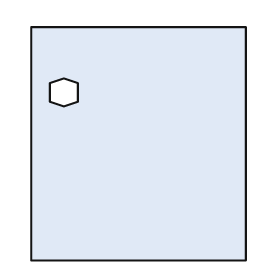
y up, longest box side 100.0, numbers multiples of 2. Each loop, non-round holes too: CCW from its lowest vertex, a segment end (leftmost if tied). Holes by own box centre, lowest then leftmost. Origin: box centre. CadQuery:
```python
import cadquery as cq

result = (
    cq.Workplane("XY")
    .moveTo(-46.0, -50.0)
    .lineTo(46.0, -50.0)
    .lineTo(46.0, 50.0)
    .lineTo(-46.0, 50.0)
    .close()
    .moveTo(-32.0, 16.0)
    .lineTo(-26.0, 18.0)
    .lineTo(-26.0, 26.0)
    .lineTo(-32.0, 28.0)
    .lineTo(-38.0, 26.0)
    .lineTo(-38.0, 18.0)
    .close()
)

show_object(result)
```